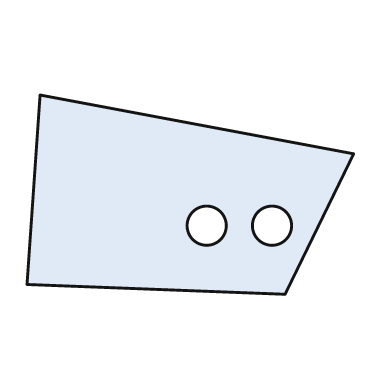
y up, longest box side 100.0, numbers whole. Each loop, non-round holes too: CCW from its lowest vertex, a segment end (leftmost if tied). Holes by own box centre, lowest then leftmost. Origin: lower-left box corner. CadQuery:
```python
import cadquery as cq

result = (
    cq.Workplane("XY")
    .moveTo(79.0, 0.0)
    .lineTo(100.0, 43.0)
    .lineTo(4.0, 61.0)
    .lineTo(0.0, 3.0)
    .close()
    .moveTo(55.0, 21.0)
    .circle(6.0)
    .moveTo(75.0, 21.0)
    .circle(6.0)
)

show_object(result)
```